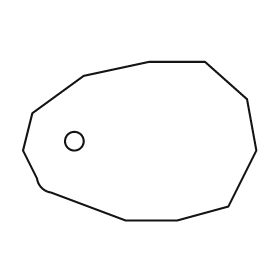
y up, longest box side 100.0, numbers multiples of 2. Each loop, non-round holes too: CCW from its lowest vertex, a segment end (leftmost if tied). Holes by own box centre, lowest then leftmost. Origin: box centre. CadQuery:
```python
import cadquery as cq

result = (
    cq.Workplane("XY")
    .moveTo(-6.0, -34.0)
    .lineTo(16.0, -34.0)
    .lineTo(38.0, -28.0)
    .lineTo(50.0, -4.0)
    .lineTo(46.0, 18.0)
    .lineTo(28.0, 34.0)
    .lineTo(4.0, 34.0)
    .lineTo(-24.0, 28.0)
    .lineTo(-46.0, 12.0)
    .lineTo(-50.0, -4.0)
    .lineTo(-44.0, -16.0)
    .threePointArc((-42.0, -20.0), (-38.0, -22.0))
    .close()
    .moveTo(-28.0, 0.0)
    .circle(4.0)
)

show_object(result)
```